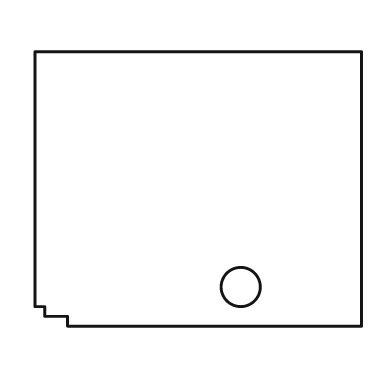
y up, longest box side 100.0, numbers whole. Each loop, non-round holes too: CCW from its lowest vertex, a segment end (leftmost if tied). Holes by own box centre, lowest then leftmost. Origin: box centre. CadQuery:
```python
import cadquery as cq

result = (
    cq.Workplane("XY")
    .moveTo(-40.0, -42.0)
    .lineTo(50.0, -42.0)
    .lineTo(50.0, 42.0)
    .lineTo(-50.0, 42.0)
    .lineTo(-50.0, -36.0)
    .lineTo(-47.0, -36.0)
    .lineTo(-47.0, -39.0)
    .lineTo(-40.0, -39.0)
    .close()
    .moveTo(13.0, -30.0)
    .circle(6.0)
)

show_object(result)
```